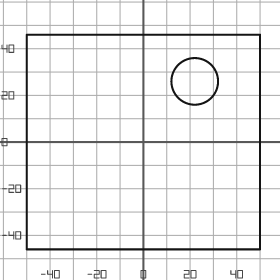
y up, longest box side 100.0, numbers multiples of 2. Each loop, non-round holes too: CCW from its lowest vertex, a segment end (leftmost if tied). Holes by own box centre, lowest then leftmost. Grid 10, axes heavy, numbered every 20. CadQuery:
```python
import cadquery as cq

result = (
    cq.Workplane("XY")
    .moveTo(-50.0, -46.0)
    .lineTo(50.0, -46.0)
    .lineTo(50.0, 46.0)
    .lineTo(-50.0, 46.0)
    .close()
    .moveTo(22.0, 26.0)
    .circle(10.0)
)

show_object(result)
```